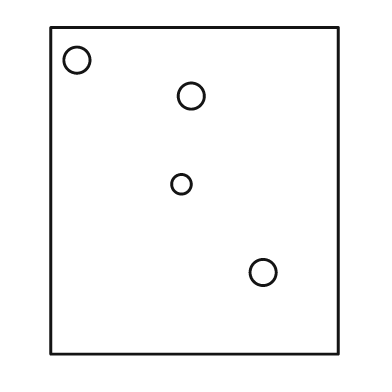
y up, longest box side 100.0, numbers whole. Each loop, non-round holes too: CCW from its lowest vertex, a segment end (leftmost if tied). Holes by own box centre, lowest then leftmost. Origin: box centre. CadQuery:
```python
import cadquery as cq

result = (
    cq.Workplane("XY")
    .moveTo(-44.0, -50.0)
    .lineTo(44.0, -50.0)
    .lineTo(44.0, 50.0)
    .lineTo(-44.0, 50.0)
    .close()
    .moveTo(21.0, -25.0)
    .circle(4.0)
    .moveTo(-4.0, 2.0)
    .circle(3.0)
    .moveTo(-1.0, 29.0)
    .circle(4.0)
    .moveTo(-36.0, 40.0)
    .circle(4.0)
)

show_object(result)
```